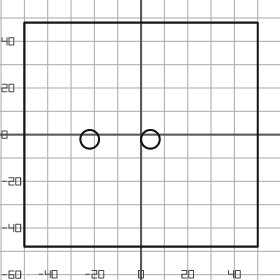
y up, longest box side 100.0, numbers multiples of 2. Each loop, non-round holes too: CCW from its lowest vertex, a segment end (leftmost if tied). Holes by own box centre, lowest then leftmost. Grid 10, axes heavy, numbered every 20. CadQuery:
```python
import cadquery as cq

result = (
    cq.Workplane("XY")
    .moveTo(-50.0, -48.0)
    .lineTo(50.0, -48.0)
    .lineTo(50.0, 48.0)
    .lineTo(-50.0, 48.0)
    .close()
    .moveTo(-22.0, -2.0)
    .circle(4.0)
    .moveTo(4.0, -2.0)
    .circle(4.0)
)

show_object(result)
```